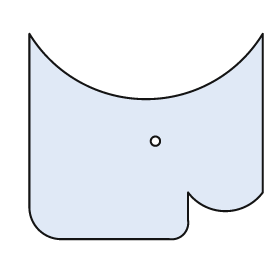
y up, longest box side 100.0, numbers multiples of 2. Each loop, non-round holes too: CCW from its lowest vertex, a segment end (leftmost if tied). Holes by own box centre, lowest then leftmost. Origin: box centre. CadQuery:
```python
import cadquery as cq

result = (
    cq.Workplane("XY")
    .moveTo(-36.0, -44.0)
    .lineTo(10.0, -44.0)
    .threePointArc((16.0, -42.0), (18.0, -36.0))
    .lineTo(18.0, -24.0)
    .threePointArc((34.0, -32.0), (50.0, -24.0))
    .lineTo(50.0, 44.0)
    .threePointArc((0.0, 16.0), (-50.0, 44.0))
    .lineTo(-50.0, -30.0)
    .threePointArc((-46.0, -40.0), (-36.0, -44.0))
    .close()
    .moveTo(4.0, -2.0)
    .circle(2.0)
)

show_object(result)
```